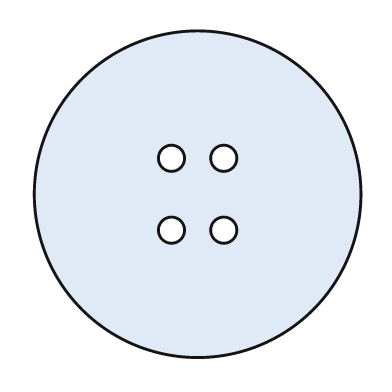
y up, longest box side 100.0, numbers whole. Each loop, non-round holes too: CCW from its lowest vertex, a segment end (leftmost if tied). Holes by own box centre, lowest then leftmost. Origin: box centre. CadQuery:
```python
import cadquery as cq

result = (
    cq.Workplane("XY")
    .moveTo(0.0, 0.0)
    .circle(50.0)
    .moveTo(-8.0, -11.0)
    .circle(4.0)
    .moveTo(8.0, -11.0)
    .circle(4.0)
    .moveTo(-8.0, 11.0)
    .circle(4.0)
    .moveTo(8.0, 11.0)
    .circle(4.0)
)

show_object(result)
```